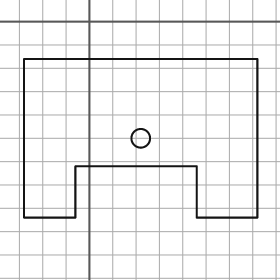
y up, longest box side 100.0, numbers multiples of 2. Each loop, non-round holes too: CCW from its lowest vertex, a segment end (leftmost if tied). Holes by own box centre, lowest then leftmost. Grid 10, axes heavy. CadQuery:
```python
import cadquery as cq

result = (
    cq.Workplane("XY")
    .moveTo(-28.0, -84.0)
    .lineTo(-6.0, -84.0)
    .lineTo(-6.0, -62.0)
    .lineTo(46.0, -62.0)
    .lineTo(46.0, -84.0)
    .lineTo(72.0, -84.0)
    .lineTo(72.0, -16.0)
    .lineTo(-28.0, -16.0)
    .close()
    .moveTo(22.0, -50.0)
    .circle(4.0)
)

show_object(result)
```